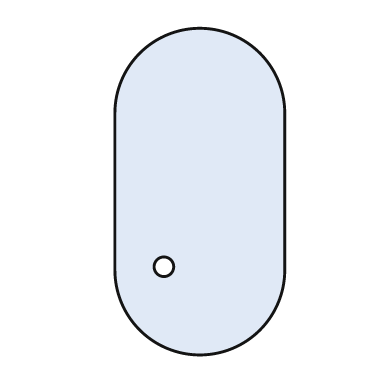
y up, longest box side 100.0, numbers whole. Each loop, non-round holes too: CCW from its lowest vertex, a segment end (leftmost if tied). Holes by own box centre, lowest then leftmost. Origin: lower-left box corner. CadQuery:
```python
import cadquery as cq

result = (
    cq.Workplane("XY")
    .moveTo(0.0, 26.0)
    .threePointArc((26.0, 0.0), (52.0, 26.0))
    .lineTo(52.0, 74.0)
    .threePointArc((26.0, 100.0), (0.0, 74.0))
    .close()
    .moveTo(15.0, 27.0)
    .circle(3.0)
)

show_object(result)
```